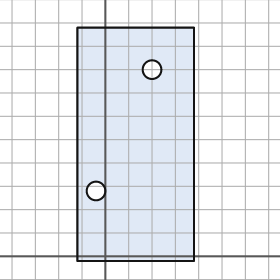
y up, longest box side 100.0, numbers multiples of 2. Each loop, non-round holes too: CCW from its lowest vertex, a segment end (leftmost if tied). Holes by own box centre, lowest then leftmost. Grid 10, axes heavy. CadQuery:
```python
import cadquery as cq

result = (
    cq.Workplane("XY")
    .moveTo(-12.0, -2.0)
    .lineTo(38.0, -2.0)
    .lineTo(38.0, 98.0)
    .lineTo(-12.0, 98.0)
    .close()
    .moveTo(-4.0, 28.0)
    .circle(4.0)
    .moveTo(20.0, 80.0)
    .circle(4.0)
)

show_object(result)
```